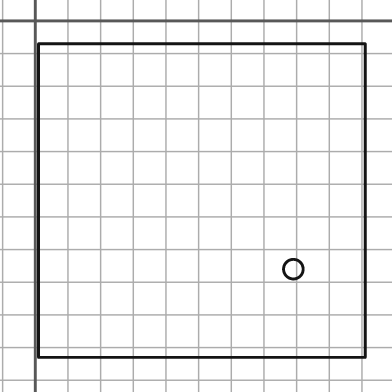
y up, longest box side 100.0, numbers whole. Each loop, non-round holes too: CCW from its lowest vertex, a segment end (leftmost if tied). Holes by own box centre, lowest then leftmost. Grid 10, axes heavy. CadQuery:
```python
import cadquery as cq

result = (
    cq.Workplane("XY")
    .moveTo(1.0, -103.0)
    .lineTo(101.0, -103.0)
    .lineTo(101.0, -7.0)
    .lineTo(1.0, -7.0)
    .close()
    .moveTo(79.0, -76.0)
    .circle(3.0)
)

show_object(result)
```